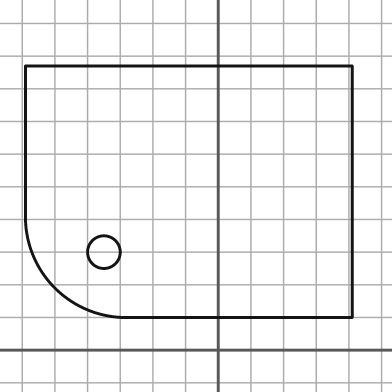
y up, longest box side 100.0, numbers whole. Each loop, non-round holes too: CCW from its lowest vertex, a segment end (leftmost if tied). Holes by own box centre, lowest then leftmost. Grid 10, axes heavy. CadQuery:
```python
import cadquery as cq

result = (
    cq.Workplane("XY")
    .moveTo(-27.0, 10.0)
    .lineTo(41.0, 10.0)
    .lineTo(41.0, 87.0)
    .lineTo(-59.0, 87.0)
    .lineTo(-59.0, 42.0)
    .threePointArc((-50.0, 19.0), (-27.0, 10.0))
    .close()
    .moveTo(-35.0, 30.0)
    .circle(5.0)
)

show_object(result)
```